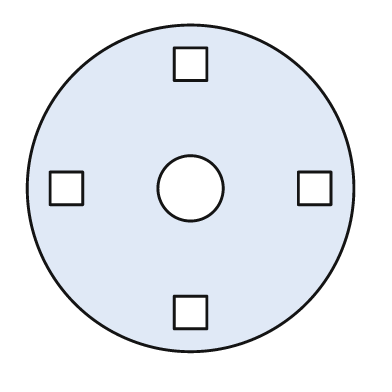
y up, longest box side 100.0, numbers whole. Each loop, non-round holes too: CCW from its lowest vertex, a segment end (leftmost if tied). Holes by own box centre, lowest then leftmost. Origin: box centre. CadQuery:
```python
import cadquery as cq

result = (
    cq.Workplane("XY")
    .moveTo(0.0, 0.0)
    .circle(50.0)
    .moveTo(-5.0, -43.0)
    .lineTo(5.0, -43.0)
    .lineTo(5.0, -33.0)
    .lineTo(-5.0, -33.0)
    .close()
    .moveTo(-43.0, -5.0)
    .lineTo(-33.0, -5.0)
    .lineTo(-33.0, 5.0)
    .lineTo(-43.0, 5.0)
    .close()
    .moveTo(0.0, 0.0)
    .circle(10.0)
    .moveTo(33.0, -5.0)
    .lineTo(43.0, -5.0)
    .lineTo(43.0, 5.0)
    .lineTo(33.0, 5.0)
    .close()
    .moveTo(-5.0, 33.0)
    .lineTo(5.0, 33.0)
    .lineTo(5.0, 43.0)
    .lineTo(-5.0, 43.0)
    .close()
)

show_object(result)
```